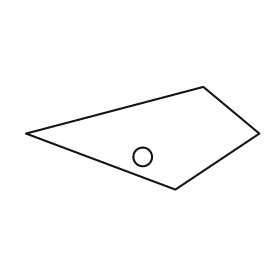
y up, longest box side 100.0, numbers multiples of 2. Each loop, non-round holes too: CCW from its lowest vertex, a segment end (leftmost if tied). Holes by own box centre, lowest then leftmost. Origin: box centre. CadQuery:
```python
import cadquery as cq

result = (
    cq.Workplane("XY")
    .moveTo(14.0, -22.0)
    .lineTo(50.0, 2.0)
    .lineTo(26.0, 22.0)
    .lineTo(-50.0, 2.0)
    .close()
    .moveTo(0.0, -8.0)
    .circle(4.0)
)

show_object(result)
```